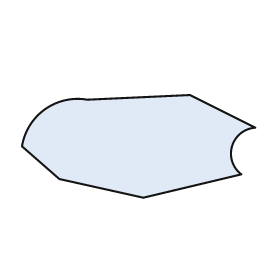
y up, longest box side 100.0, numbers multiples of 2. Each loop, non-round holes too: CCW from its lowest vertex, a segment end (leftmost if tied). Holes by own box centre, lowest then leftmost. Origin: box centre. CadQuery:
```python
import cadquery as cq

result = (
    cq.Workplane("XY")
    .moveTo(2.0, -22.0)
    .lineTo(44.0, -12.0)
    .threePointArc((40.0, 0.0), (50.0, 8.0))
    .lineTo(22.0, 22.0)
    .lineTo(-22.0, 20.0)
    .threePointArc((-40.0, 16.0), (-50.0, 0.0))
    .lineTo(-34.0, -14.0)
    .close()
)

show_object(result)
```